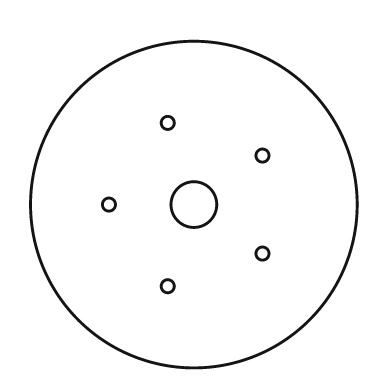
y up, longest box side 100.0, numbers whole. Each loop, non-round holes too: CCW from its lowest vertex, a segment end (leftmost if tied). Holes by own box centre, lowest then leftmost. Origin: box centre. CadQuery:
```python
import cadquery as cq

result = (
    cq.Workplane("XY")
    .moveTo(0.0, 0.0)
    .circle(50.0)
    .moveTo(-8.0, -25.0)
    .circle(2.0)
    .moveTo(21.0, -15.0)
    .circle(2.0)
    .moveTo(-26.0, 0.0)
    .circle(2.0)
    .moveTo(0.0, 0.0)
    .circle(7.0)
    .moveTo(21.0, 15.0)
    .circle(2.0)
    .moveTo(-8.0, 25.0)
    .circle(2.0)
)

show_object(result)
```